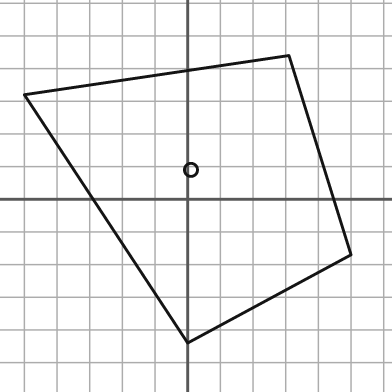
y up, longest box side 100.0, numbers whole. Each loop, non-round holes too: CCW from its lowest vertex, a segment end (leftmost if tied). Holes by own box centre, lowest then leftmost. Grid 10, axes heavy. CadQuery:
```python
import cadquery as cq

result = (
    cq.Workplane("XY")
    .moveTo(0.0, -44.0)
    .lineTo(50.0, -17.0)
    .lineTo(31.0, 44.0)
    .lineTo(-50.0, 32.0)
    .close()
    .moveTo(1.0, 9.0)
    .circle(2.0)
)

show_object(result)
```